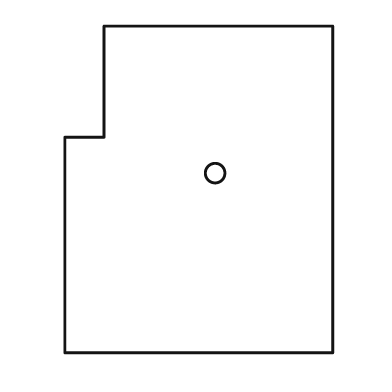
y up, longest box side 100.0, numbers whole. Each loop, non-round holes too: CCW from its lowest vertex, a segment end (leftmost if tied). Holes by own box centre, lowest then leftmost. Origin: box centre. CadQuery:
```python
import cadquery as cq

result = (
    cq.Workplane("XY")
    .moveTo(-41.0, -50.0)
    .lineTo(41.0, -50.0)
    .lineTo(41.0, 50.0)
    .lineTo(-29.0, 50.0)
    .lineTo(-29.0, 16.0)
    .lineTo(-41.0, 16.0)
    .close()
    .moveTo(5.0, 5.0)
    .circle(3.0)
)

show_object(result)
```